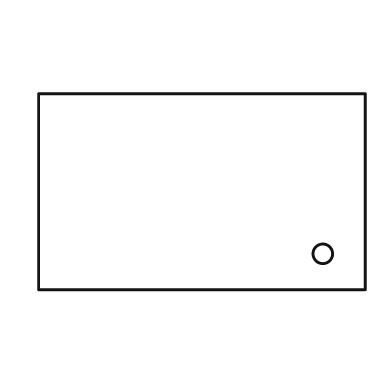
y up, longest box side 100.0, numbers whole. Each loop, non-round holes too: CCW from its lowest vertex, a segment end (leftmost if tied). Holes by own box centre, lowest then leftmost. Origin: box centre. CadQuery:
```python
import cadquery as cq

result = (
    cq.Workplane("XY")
    .moveTo(-50.0, -30.0)
    .lineTo(50.0, -30.0)
    .lineTo(50.0, 30.0)
    .lineTo(-50.0, 30.0)
    .close()
    .moveTo(37.0, -19.0)
    .circle(3.0)
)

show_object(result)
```